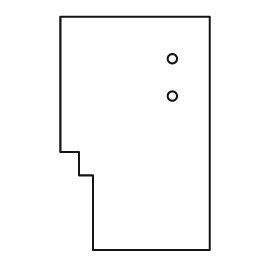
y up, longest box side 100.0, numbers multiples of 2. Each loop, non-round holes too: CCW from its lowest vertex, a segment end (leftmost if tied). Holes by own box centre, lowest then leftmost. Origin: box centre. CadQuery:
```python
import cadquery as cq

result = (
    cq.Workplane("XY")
    .moveTo(-18.0, -50.0)
    .lineTo(32.0, -50.0)
    .lineTo(32.0, 50.0)
    .lineTo(-32.0, 50.0)
    .lineTo(-32.0, -8.0)
    .lineTo(-24.0, -8.0)
    .lineTo(-24.0, -18.0)
    .lineTo(-18.0, -18.0)
    .close()
    .moveTo(16.0, 16.0)
    .circle(2.0)
    .moveTo(16.0, 32.0)
    .circle(2.0)
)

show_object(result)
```